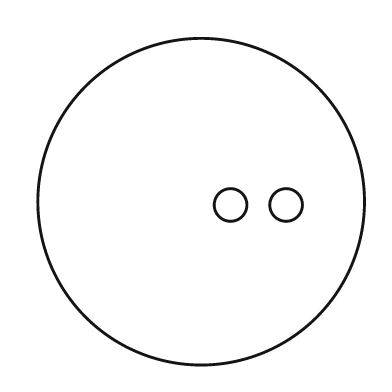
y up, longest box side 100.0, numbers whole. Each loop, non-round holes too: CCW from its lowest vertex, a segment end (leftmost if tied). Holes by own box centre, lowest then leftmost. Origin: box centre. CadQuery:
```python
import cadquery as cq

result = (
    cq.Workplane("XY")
    .moveTo(0.0, 0.0)
    .circle(50.0)
    .moveTo(9.0, -1.0)
    .circle(5.0)
    .moveTo(26.0, -1.0)
    .circle(5.0)
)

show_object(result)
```